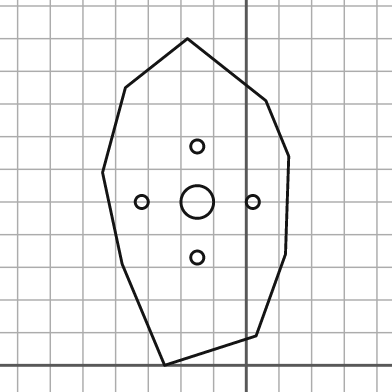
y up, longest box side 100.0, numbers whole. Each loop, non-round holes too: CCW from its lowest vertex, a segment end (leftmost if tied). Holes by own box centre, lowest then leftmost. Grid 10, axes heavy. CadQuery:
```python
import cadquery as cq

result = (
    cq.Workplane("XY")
    .moveTo(-25.0, 0.0)
    .lineTo(3.0, 9.0)
    .lineTo(12.0, 34.0)
    .lineTo(13.0, 64.0)
    .lineTo(6.0, 81.0)
    .lineTo(-18.0, 100.0)
    .lineTo(-37.0, 85.0)
    .lineTo(-44.0, 59.0)
    .lineTo(-38.0, 31.0)
    .close()
    .moveTo(-15.0, 33.0)
    .circle(2.0)
    .moveTo(-32.0, 50.0)
    .circle(2.0)
    .moveTo(-15.0, 50.0)
    .circle(5.0)
    .moveTo(2.0, 50.0)
    .circle(2.0)
    .moveTo(-15.0, 67.0)
    .circle(2.0)
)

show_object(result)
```